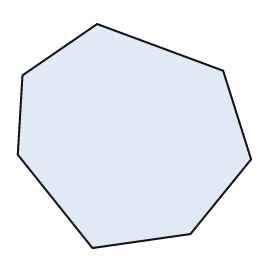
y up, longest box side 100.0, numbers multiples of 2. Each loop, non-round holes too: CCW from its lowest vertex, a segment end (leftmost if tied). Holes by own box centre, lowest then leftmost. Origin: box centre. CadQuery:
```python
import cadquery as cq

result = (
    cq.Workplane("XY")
    .moveTo(-18.0, -48.0)
    .lineTo(24.0, -42.0)
    .lineTo(50.0, -10.0)
    .lineTo(38.0, 28.0)
    .lineTo(-16.0, 48.0)
    .lineTo(-48.0, 26.0)
    .lineTo(-50.0, -8.0)
    .close()
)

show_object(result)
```